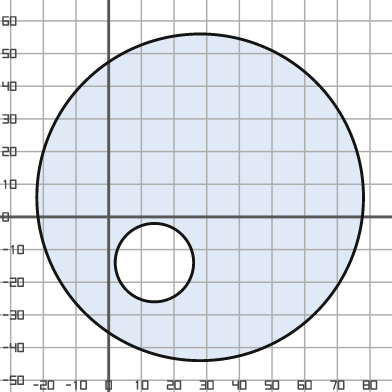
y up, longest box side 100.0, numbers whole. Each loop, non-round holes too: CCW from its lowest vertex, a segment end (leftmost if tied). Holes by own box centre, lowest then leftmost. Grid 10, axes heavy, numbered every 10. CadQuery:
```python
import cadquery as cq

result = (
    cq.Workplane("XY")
    .moveTo(28.0, 6.0)
    .circle(50.0)
    .moveTo(14.0, -14.0)
    .circle(12.0)
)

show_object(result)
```